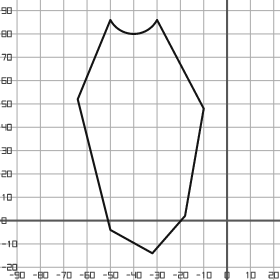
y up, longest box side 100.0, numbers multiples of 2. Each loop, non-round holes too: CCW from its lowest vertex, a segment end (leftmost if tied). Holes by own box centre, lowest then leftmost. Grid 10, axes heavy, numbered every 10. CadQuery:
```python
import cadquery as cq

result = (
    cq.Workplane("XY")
    .moveTo(-32.0, -14.0)
    .lineTo(-18.0, 2.0)
    .lineTo(-10.0, 48.0)
    .lineTo(-30.0, 86.0)
    .threePointArc((-40.0, 80.0), (-50.0, 86.0))
    .lineTo(-64.0, 52.0)
    .lineTo(-50.0, -4.0)
    .close()
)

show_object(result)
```